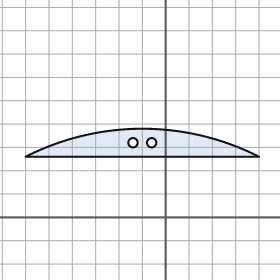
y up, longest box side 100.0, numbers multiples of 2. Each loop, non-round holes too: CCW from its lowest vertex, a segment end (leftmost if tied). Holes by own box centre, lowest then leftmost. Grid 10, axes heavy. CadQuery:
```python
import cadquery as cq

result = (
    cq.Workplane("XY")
    .moveTo(-60.0, 26.0)
    .lineTo(40.0, 26.0)
    .threePointArc((-10.0, 38.0), (-60.0, 26.0))
    .close()
    .moveTo(-14.0, 32.0)
    .circle(2.0)
    .moveTo(-6.0, 32.0)
    .circle(2.0)
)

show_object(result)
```